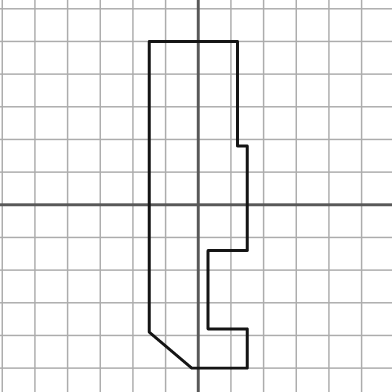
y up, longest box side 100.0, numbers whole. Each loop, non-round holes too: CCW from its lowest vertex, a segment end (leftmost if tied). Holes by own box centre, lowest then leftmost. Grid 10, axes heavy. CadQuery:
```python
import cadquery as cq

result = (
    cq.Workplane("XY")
    .moveTo(-2.0, -50.0)
    .lineTo(15.0, -50.0)
    .lineTo(15.0, -38.0)
    .lineTo(3.0, -38.0)
    .lineTo(3.0, -14.0)
    .lineTo(15.0, -14.0)
    .lineTo(15.0, 18.0)
    .lineTo(12.0, 18.0)
    .lineTo(12.0, 50.0)
    .lineTo(-15.0, 50.0)
    .lineTo(-15.0, -39.0)
    .close()
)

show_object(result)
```